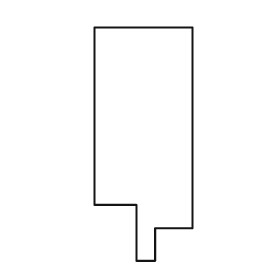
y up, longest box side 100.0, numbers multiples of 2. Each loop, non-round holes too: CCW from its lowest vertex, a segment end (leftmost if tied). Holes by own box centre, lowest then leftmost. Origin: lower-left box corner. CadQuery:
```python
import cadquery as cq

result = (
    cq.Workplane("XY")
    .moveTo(18.0, 0.0)
    .lineTo(26.0, 0.0)
    .lineTo(26.0, 14.0)
    .lineTo(42.0, 14.0)
    .lineTo(42.0, 100.0)
    .lineTo(0.0, 100.0)
    .lineTo(0.0, 24.0)
    .lineTo(18.0, 24.0)
    .close()
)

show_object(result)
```